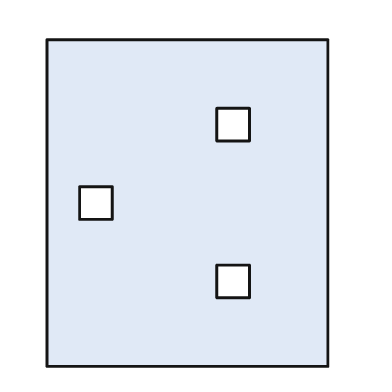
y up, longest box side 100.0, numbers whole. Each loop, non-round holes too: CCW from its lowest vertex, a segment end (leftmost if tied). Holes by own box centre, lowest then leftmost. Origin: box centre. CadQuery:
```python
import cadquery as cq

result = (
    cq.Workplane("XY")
    .moveTo(-43.0, -50.0)
    .lineTo(43.0, -50.0)
    .lineTo(43.0, 50.0)
    .lineTo(-43.0, 50.0)
    .close()
    .moveTo(9.0, -29.0)
    .lineTo(19.0, -29.0)
    .lineTo(19.0, -19.0)
    .lineTo(9.0, -19.0)
    .close()
    .moveTo(-33.0, -5.0)
    .lineTo(-23.0, -5.0)
    .lineTo(-23.0, 5.0)
    .lineTo(-33.0, 5.0)
    .close()
    .moveTo(9.0, 19.0)
    .lineTo(19.0, 19.0)
    .lineTo(19.0, 29.0)
    .lineTo(9.0, 29.0)
    .close()
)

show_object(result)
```